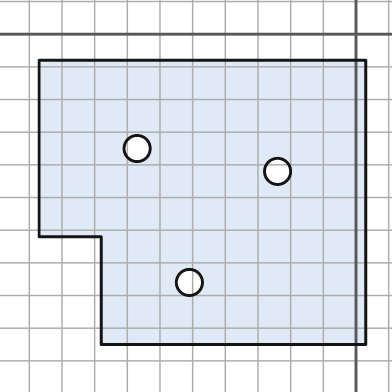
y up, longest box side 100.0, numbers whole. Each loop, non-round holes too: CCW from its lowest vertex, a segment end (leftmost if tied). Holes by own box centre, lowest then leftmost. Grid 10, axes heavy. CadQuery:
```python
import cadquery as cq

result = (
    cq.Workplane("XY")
    .moveTo(-78.0, -95.0)
    .lineTo(3.0, -95.0)
    .lineTo(3.0, -8.0)
    .lineTo(-97.0, -8.0)
    .lineTo(-97.0, -62.0)
    .lineTo(-78.0, -62.0)
    .close()
    .moveTo(-51.0, -76.0)
    .circle(4.0)
    .moveTo(-24.0, -42.0)
    .circle(4.0)
    .moveTo(-67.0, -35.0)
    .circle(4.0)
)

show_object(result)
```